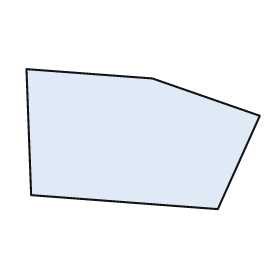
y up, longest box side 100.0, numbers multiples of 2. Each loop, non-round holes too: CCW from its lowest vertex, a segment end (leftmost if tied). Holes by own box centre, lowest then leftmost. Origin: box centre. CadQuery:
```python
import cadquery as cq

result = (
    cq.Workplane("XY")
    .moveTo(32.0, -30.0)
    .lineTo(50.0, 10.0)
    .lineTo(4.0, 26.0)
    .lineTo(-50.0, 30.0)
    .lineTo(-48.0, -24.0)
    .close()
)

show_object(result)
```